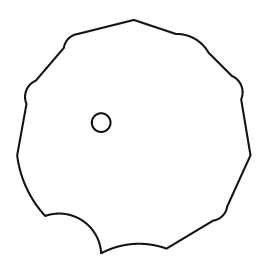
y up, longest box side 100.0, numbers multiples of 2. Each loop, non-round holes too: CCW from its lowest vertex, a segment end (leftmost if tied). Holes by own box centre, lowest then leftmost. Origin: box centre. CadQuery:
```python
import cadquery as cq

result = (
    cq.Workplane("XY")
    .moveTo(-14.0, -50.0)
    .threePointArc((0.0, -46.0), (14.0, -48.0))
    .lineTo(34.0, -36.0)
    .threePointArc((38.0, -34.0), (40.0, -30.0))
    .lineTo(50.0, -8.0)
    .lineTo(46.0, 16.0)
    .threePointArc((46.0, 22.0), (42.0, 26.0))
    .lineTo(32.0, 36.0)
    .threePointArc((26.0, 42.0), (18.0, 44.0))
    .lineTo(0.0, 50.0)
    .lineTo(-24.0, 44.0)
    .threePointArc((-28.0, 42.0), (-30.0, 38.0))
    .lineTo(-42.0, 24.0)
    .threePointArc((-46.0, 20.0), (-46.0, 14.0))
    .lineTo(-50.0, -8.0)
    .threePointArc((-46.0, -22.0), (-38.0, -34.0))
    .threePointArc((-22.0, -36.0), (-14.0, -50.0))
    .close()
    .moveTo(-14.0, 6.0)
    .circle(4.0)
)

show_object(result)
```